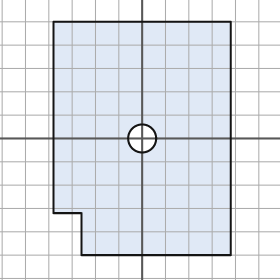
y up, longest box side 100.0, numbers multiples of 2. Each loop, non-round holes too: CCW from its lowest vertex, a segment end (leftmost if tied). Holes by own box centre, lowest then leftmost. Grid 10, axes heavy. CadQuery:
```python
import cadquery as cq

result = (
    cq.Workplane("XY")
    .moveTo(-26.0, -50.0)
    .lineTo(38.0, -50.0)
    .lineTo(38.0, 50.0)
    .lineTo(-38.0, 50.0)
    .lineTo(-38.0, -32.0)
    .lineTo(-26.0, -32.0)
    .close()
    .moveTo(0.0, 0.0)
    .circle(6.0)
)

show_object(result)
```